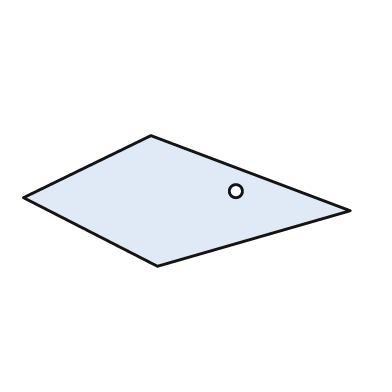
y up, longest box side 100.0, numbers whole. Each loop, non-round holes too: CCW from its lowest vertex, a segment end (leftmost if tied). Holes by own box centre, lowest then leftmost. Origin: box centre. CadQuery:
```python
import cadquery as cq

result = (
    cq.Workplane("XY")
    .moveTo(-9.0, -20.0)
    .lineTo(50.0, -3.0)
    .lineTo(-11.0, 20.0)
    .lineTo(-50.0, 1.0)
    .close()
    .moveTo(15.0, 3.0)
    .circle(2.0)
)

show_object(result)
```